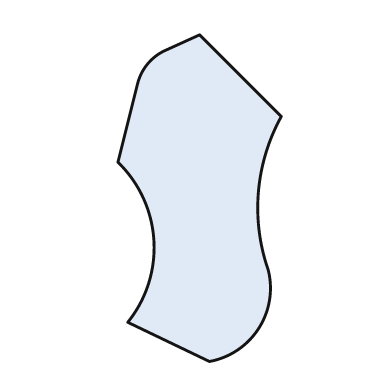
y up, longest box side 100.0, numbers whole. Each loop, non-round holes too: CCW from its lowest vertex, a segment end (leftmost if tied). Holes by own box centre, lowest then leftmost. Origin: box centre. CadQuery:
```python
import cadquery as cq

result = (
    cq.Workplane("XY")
    .moveTo(3.0, -50.0)
    .threePointArc((18.0, -40.0), (21.0, -22.0))
    .threePointArc((18.0, 2.0), (25.0, 25.0))
    .lineTo(0.0, 50.0)
    .lineTo(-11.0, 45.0)
    .threePointArc((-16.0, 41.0), (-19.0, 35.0))
    .lineTo(-25.0, 11.0)
    .threePointArc((-14.0, -13.0), (-22.0, -38.0))
    .close()
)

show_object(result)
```